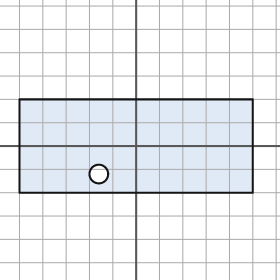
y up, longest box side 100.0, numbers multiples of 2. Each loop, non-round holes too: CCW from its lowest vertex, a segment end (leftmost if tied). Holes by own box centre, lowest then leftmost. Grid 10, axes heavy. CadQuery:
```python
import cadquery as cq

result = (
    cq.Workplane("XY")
    .moveTo(-50.0, -20.0)
    .lineTo(50.0, -20.0)
    .lineTo(50.0, 20.0)
    .lineTo(-50.0, 20.0)
    .close()
    .moveTo(-16.0, -12.0)
    .circle(4.0)
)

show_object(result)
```